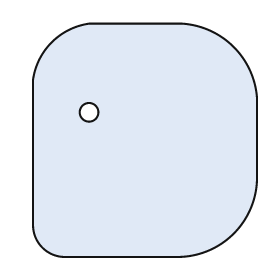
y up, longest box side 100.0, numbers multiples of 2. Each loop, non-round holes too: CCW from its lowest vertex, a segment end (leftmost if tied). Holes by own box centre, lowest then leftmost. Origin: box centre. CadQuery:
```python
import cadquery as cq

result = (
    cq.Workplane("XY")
    .moveTo(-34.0, -50.0)
    .lineTo(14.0, -50.0)
    .threePointArc((38.0, -40.0), (48.0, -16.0))
    .lineTo(48.0, 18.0)
    .threePointArc((38.0, 40.0), (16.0, 50.0))
    .lineTo(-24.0, 50.0)
    .threePointArc((-40.0, 42.0), (-48.0, 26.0))
    .lineTo(-48.0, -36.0)
    .threePointArc((-44.0, -46.0), (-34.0, -50.0))
    .close()
    .moveTo(-24.0, 12.0)
    .circle(4.0)
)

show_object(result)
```